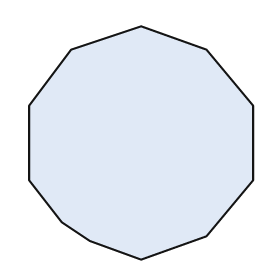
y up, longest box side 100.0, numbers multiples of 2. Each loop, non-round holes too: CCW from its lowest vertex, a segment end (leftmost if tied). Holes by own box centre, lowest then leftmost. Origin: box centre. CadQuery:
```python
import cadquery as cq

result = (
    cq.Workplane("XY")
    .moveTo(0.0, -50.0)
    .lineTo(28.0, -40.0)
    .lineTo(48.0, -16.0)
    .lineTo(48.0, 16.0)
    .lineTo(28.0, 40.0)
    .lineTo(0.0, 50.0)
    .lineTo(-30.0, 40.0)
    .lineTo(-48.0, 16.0)
    .lineTo(-48.0, -16.0)
    .lineTo(-34.0, -34.0)
    .lineTo(-22.0, -42.0)
    .close()
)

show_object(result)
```